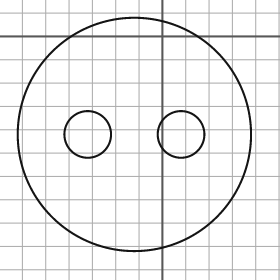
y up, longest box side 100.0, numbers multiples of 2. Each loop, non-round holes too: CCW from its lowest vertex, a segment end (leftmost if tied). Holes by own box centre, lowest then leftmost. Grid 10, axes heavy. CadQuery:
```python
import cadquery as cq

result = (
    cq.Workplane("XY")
    .moveTo(-12.0, -42.0)
    .circle(50.0)
    .moveTo(-32.0, -42.0)
    .circle(10.0)
    .moveTo(8.0, -42.0)
    .circle(10.0)
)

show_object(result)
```